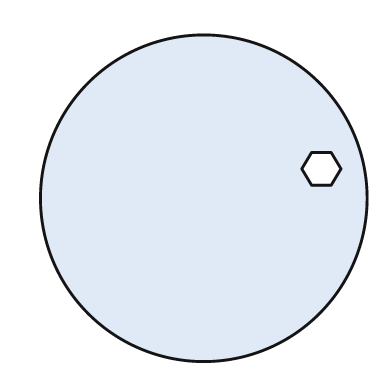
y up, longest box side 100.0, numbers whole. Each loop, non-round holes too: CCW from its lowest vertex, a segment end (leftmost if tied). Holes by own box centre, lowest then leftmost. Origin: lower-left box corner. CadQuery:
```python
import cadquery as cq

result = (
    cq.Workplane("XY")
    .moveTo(50.0, 50.0)
    .circle(50.0)
    .moveTo(83.0, 54.0)
    .lineTo(89.0, 54.0)
    .lineTo(92.0, 59.0)
    .lineTo(89.0, 64.0)
    .lineTo(83.0, 64.0)
    .lineTo(80.0, 59.0)
    .close()
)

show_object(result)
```